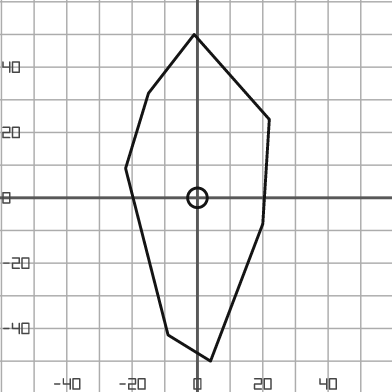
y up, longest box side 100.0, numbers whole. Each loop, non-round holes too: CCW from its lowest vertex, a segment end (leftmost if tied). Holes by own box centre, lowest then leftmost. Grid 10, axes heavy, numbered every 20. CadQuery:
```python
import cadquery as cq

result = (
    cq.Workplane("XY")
    .moveTo(4.0, -50.0)
    .lineTo(20.0, -8.0)
    .lineTo(22.0, 24.0)
    .lineTo(-1.0, 50.0)
    .lineTo(-15.0, 32.0)
    .lineTo(-22.0, 9.0)
    .lineTo(-9.0, -42.0)
    .close()
    .moveTo(0.0, 0.0)
    .circle(3.0)
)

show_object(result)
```